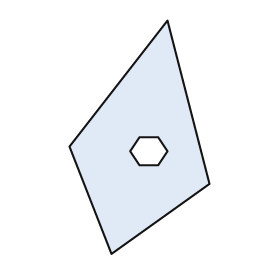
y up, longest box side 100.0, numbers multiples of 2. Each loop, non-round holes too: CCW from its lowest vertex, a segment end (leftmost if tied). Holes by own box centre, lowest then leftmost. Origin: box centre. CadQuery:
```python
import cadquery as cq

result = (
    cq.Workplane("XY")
    .moveTo(-12.0, -50.0)
    .lineTo(30.0, -20.0)
    .lineTo(12.0, 50.0)
    .lineTo(-30.0, -4.0)
    .close()
    .moveTo(0.0, -12.0)
    .lineTo(8.0, -12.0)
    .lineTo(12.0, -6.0)
    .lineTo(8.0, 0.0)
    .lineTo(0.0, 0.0)
    .lineTo(-4.0, -6.0)
    .close()
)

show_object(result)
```